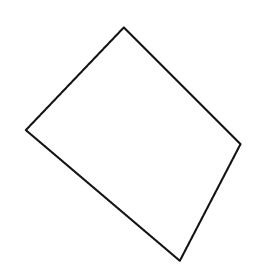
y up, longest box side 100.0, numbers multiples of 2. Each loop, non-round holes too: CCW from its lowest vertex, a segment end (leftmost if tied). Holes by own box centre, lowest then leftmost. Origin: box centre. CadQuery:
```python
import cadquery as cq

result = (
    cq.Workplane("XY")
    .moveTo(20.0, -50.0)
    .lineTo(46.0, 0.0)
    .lineTo(-4.0, 50.0)
    .lineTo(-46.0, 6.0)
    .close()
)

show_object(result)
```